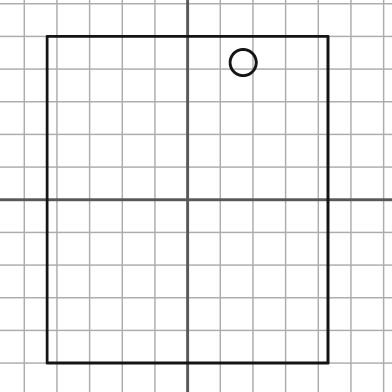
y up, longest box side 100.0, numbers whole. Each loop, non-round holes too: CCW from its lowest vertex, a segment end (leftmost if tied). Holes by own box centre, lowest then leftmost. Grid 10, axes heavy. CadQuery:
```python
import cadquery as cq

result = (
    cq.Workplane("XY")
    .moveTo(-43.0, -50.0)
    .lineTo(43.0, -50.0)
    .lineTo(43.0, 50.0)
    .lineTo(-43.0, 50.0)
    .close()
    .moveTo(17.0, 42.0)
    .circle(4.0)
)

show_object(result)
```